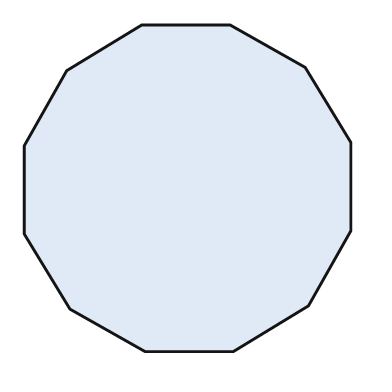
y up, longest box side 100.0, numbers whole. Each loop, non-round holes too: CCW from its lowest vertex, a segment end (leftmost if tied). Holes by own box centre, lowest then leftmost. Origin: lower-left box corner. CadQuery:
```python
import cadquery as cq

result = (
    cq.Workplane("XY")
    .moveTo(37.0, 0.0)
    .lineTo(64.0, 0.0)
    .lineTo(87.0, 14.0)
    .lineTo(100.0, 37.0)
    .lineTo(100.0, 64.0)
    .lineTo(86.0, 87.0)
    .lineTo(63.0, 100.0)
    .lineTo(36.0, 100.0)
    .lineTo(13.0, 86.0)
    .lineTo(0.0, 63.0)
    .lineTo(0.0, 36.0)
    .lineTo(14.0, 13.0)
    .close()
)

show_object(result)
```